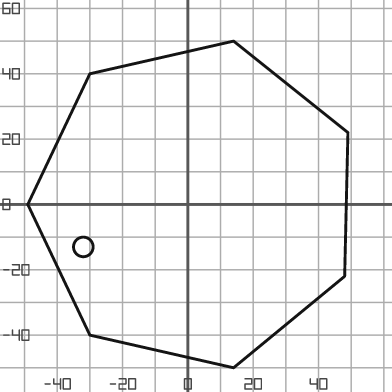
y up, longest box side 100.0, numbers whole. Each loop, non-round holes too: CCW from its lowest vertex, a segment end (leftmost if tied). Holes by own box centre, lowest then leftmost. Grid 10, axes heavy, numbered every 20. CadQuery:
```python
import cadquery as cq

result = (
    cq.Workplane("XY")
    .moveTo(14.0, -50.0)
    .lineTo(48.0, -22.0)
    .lineTo(49.0, 22.0)
    .lineTo(14.0, 50.0)
    .lineTo(-30.0, 40.0)
    .lineTo(-49.0, 0.0)
    .lineTo(-30.0, -40.0)
    .close()
    .moveTo(-32.0, -13.0)
    .circle(3.0)
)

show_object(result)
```